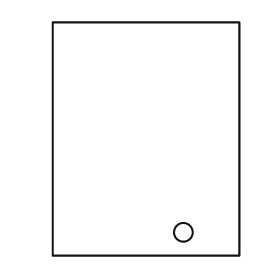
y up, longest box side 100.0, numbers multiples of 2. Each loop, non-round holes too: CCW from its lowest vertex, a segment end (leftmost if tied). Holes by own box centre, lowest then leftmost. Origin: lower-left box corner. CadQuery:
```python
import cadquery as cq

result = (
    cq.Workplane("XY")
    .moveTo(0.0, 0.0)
    .lineTo(80.0, 0.0)
    .lineTo(80.0, 100.0)
    .lineTo(0.0, 100.0)
    .close()
    .moveTo(56.0, 10.0)
    .circle(4.0)
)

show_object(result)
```